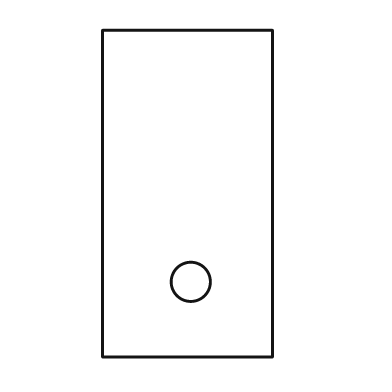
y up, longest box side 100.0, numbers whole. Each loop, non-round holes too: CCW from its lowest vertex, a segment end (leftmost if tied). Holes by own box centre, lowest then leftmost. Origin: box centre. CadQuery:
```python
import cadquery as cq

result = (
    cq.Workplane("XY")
    .moveTo(-26.0, -50.0)
    .lineTo(26.0, -50.0)
    .lineTo(26.0, 50.0)
    .lineTo(-26.0, 50.0)
    .close()
    .moveTo(1.0, -27.0)
    .circle(6.0)
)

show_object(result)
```